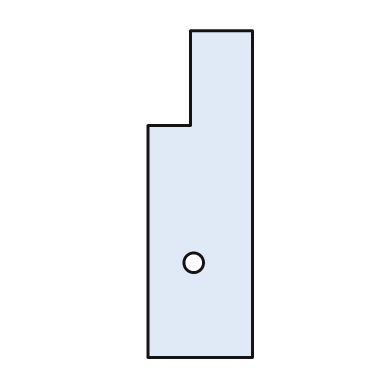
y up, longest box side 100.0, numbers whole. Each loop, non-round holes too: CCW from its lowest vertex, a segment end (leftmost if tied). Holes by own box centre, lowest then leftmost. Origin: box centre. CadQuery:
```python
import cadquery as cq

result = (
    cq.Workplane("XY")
    .moveTo(-16.0, -50.0)
    .lineTo(16.0, -50.0)
    .lineTo(16.0, 50.0)
    .lineTo(-3.0, 50.0)
    .lineTo(-3.0, 21.0)
    .lineTo(-16.0, 21.0)
    .close()
    .moveTo(-2.0, -21.0)
    .circle(3.0)
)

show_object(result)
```